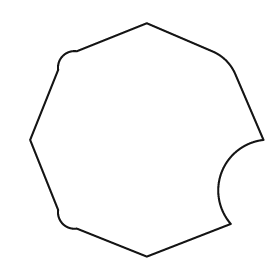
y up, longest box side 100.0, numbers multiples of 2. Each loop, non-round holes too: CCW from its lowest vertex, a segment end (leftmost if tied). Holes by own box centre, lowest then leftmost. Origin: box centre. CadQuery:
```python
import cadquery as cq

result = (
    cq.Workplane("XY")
    .moveTo(0.0, -50.0)
    .lineTo(36.0, -36.0)
    .threePointArc((32.0, -14.0), (50.0, 0.0))
    .lineTo(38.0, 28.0)
    .threePointArc((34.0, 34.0), (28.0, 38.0))
    .lineTo(0.0, 50.0)
    .lineTo(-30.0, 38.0)
    .threePointArc((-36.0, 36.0), (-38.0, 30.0))
    .lineTo(-50.0, 0.0)
    .lineTo(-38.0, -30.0)
    .threePointArc((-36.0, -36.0), (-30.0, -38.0))
    .close()
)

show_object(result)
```